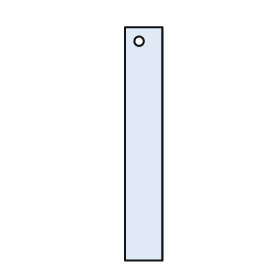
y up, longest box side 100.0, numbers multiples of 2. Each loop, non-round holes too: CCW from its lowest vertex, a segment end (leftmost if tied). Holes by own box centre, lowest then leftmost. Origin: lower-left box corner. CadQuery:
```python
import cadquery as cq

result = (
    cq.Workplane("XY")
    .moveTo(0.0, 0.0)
    .lineTo(16.0, 0.0)
    .lineTo(16.0, 100.0)
    .lineTo(0.0, 100.0)
    .close()
    .moveTo(6.0, 94.0)
    .circle(2.0)
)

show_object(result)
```